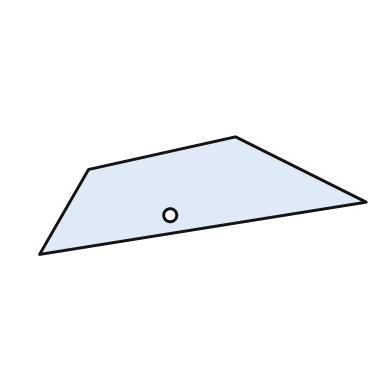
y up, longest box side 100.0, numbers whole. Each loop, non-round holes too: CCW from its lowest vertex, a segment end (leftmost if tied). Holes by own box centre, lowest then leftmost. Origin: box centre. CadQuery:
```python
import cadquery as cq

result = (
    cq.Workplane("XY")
    .moveTo(-50.0, -18.0)
    .lineTo(50.0, -2.0)
    .lineTo(10.0, 18.0)
    .lineTo(-35.0, 8.0)
    .close()
    .moveTo(-10.0, -6.0)
    .circle(2.0)
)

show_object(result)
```